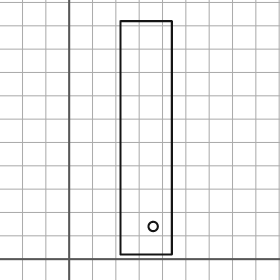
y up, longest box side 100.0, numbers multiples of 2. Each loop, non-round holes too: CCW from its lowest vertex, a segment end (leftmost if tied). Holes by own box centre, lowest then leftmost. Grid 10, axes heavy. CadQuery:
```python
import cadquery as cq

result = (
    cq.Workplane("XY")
    .moveTo(22.0, 2.0)
    .lineTo(44.0, 2.0)
    .lineTo(44.0, 102.0)
    .lineTo(22.0, 102.0)
    .close()
    .moveTo(36.0, 14.0)
    .circle(2.0)
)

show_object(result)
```